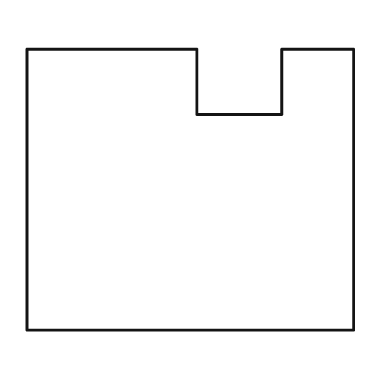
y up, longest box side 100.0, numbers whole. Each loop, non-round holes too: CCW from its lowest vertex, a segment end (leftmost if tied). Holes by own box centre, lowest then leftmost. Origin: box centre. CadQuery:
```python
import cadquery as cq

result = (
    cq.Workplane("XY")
    .moveTo(-50.0, -43.0)
    .lineTo(50.0, -43.0)
    .lineTo(50.0, 43.0)
    .lineTo(28.0, 43.0)
    .lineTo(28.0, 23.0)
    .lineTo(2.0, 23.0)
    .lineTo(2.0, 43.0)
    .lineTo(-50.0, 43.0)
    .close()
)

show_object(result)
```